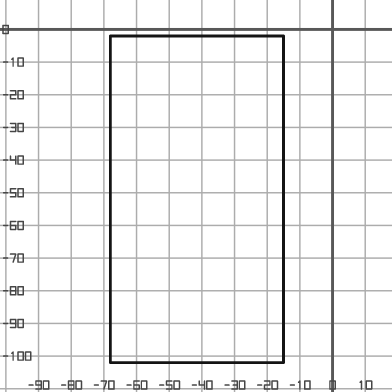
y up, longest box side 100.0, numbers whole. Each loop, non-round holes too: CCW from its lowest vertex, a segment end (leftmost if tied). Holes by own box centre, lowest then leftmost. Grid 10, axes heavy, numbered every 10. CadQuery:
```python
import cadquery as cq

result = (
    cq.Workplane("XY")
    .moveTo(-68.0, -102.0)
    .lineTo(-15.0, -102.0)
    .lineTo(-15.0, -2.0)
    .lineTo(-68.0, -2.0)
    .close()
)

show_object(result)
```